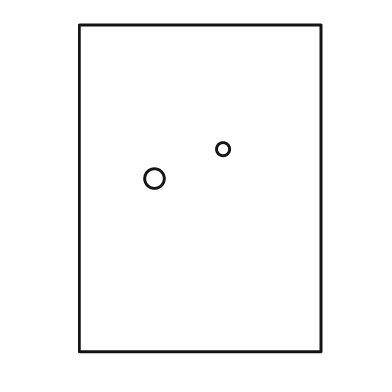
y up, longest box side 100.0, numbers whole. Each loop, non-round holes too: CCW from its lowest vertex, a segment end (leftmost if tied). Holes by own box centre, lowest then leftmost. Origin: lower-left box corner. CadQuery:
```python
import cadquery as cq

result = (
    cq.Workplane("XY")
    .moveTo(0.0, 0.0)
    .lineTo(74.0, 0.0)
    .lineTo(74.0, 100.0)
    .lineTo(0.0, 100.0)
    .close()
    .moveTo(23.0, 53.0)
    .circle(3.0)
    .moveTo(44.0, 62.0)
    .circle(2.0)
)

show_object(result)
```